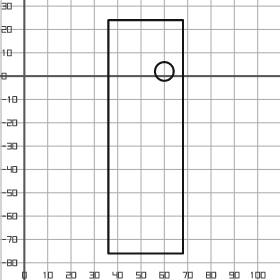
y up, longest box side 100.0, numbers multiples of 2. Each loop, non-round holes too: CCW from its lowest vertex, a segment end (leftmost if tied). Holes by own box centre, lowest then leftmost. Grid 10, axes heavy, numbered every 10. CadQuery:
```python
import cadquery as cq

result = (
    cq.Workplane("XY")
    .moveTo(36.0, -76.0)
    .lineTo(68.0, -76.0)
    .lineTo(68.0, 24.0)
    .lineTo(36.0, 24.0)
    .close()
    .moveTo(60.0, 2.0)
    .circle(4.0)
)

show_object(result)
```